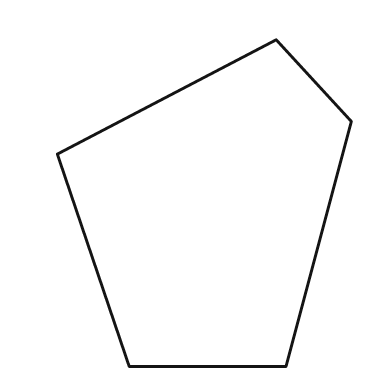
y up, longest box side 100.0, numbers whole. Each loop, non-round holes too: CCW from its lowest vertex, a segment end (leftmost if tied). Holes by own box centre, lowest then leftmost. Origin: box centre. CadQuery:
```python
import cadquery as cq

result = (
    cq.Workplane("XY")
    .moveTo(-23.0, -50.0)
    .lineTo(25.0, -50.0)
    .lineTo(45.0, 25.0)
    .lineTo(22.0, 50.0)
    .lineTo(-45.0, 15.0)
    .close()
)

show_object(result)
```